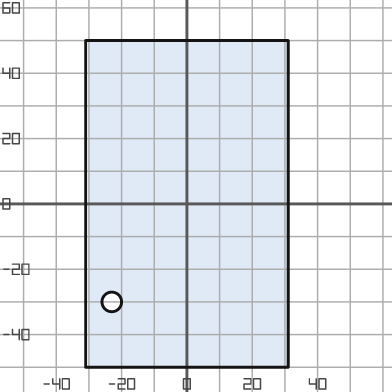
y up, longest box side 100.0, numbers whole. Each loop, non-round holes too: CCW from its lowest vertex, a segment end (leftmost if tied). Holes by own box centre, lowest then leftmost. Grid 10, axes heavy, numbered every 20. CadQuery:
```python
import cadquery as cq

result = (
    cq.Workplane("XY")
    .moveTo(-31.0, -50.0)
    .lineTo(31.0, -50.0)
    .lineTo(31.0, 50.0)
    .lineTo(-31.0, 50.0)
    .close()
    .moveTo(-23.0, -30.0)
    .circle(3.0)
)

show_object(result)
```